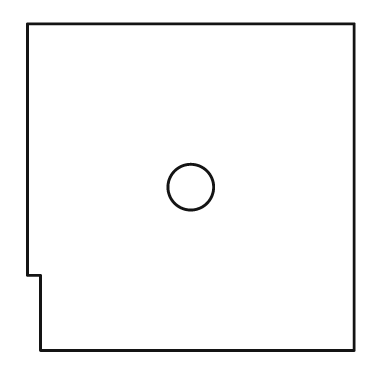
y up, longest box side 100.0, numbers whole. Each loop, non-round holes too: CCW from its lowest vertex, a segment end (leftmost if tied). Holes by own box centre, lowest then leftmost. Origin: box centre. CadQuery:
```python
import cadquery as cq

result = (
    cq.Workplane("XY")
    .moveTo(-46.0, -50.0)
    .lineTo(50.0, -50.0)
    .lineTo(50.0, 50.0)
    .lineTo(-50.0, 50.0)
    .lineTo(-50.0, -27.0)
    .lineTo(-46.0, -27.0)
    .close()
    .moveTo(0.0, 0.0)
    .circle(7.0)
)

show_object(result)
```